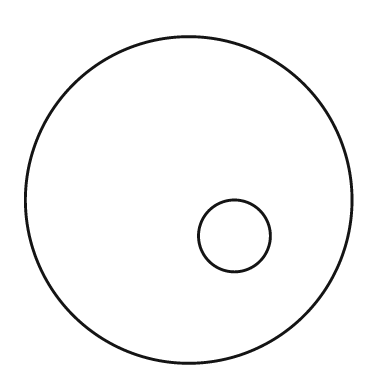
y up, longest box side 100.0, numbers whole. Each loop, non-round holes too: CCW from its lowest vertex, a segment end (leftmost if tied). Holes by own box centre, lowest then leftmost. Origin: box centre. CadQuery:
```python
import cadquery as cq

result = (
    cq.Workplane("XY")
    .moveTo(0.0, 0.0)
    .circle(50.0)
    .moveTo(14.0, -11.0)
    .circle(11.0)
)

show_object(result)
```